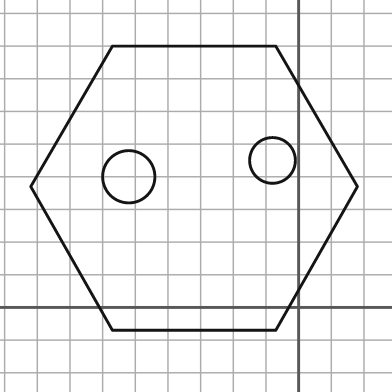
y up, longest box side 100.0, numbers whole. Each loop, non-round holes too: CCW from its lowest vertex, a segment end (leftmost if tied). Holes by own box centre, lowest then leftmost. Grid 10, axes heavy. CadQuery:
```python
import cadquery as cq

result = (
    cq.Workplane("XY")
    .moveTo(-57.0, -7.0)
    .lineTo(-7.0, -7.0)
    .lineTo(18.0, 37.0)
    .lineTo(-7.0, 80.0)
    .lineTo(-57.0, 80.0)
    .lineTo(-82.0, 37.0)
    .close()
    .moveTo(-52.0, 40.0)
    .circle(8.0)
    .moveTo(-8.0, 45.0)
    .circle(7.0)
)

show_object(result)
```